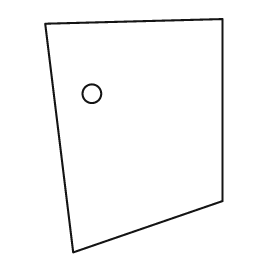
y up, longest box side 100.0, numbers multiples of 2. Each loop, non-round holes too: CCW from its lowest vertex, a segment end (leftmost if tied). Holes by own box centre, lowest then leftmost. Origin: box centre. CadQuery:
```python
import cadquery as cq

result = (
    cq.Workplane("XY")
    .moveTo(-26.0, -50.0)
    .lineTo(38.0, -28.0)
    .lineTo(38.0, 50.0)
    .lineTo(-38.0, 48.0)
    .close()
    .moveTo(-18.0, 18.0)
    .circle(4.0)
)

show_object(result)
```